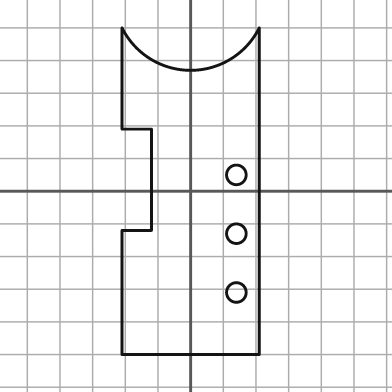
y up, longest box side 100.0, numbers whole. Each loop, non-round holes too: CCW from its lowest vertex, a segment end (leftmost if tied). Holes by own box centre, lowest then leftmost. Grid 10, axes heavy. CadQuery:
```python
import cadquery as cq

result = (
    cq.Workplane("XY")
    .moveTo(-21.0, -50.0)
    .lineTo(21.0, -50.0)
    .lineTo(21.0, 50.0)
    .threePointArc((0.0, 37.0), (-21.0, 50.0))
    .lineTo(-21.0, 19.0)
    .lineTo(-12.0, 19.0)
    .lineTo(-12.0, -12.0)
    .lineTo(-21.0, -12.0)
    .close()
    .moveTo(14.0, -31.0)
    .circle(3.0)
    .moveTo(14.0, -13.0)
    .circle(3.0)
    .moveTo(14.0, 5.0)
    .circle(3.0)
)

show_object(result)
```